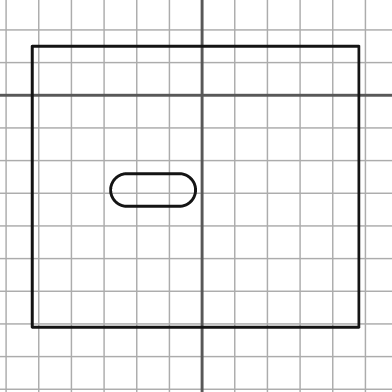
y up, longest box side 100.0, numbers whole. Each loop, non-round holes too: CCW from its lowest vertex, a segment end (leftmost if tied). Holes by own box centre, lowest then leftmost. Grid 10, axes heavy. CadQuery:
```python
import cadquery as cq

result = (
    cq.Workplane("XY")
    .moveTo(-52.0, -71.0)
    .lineTo(48.0, -71.0)
    .lineTo(48.0, 15.0)
    .lineTo(-52.0, 15.0)
    .close()
    .moveTo(-23.0, -34.0)
    .lineTo(-7.0, -34.0)
    .threePointArc((-2.0, -29.0), (-7.0, -24.0))
    .lineTo(-23.0, -24.0)
    .threePointArc((-28.0, -29.0), (-23.0, -34.0))
    .close()
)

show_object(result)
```